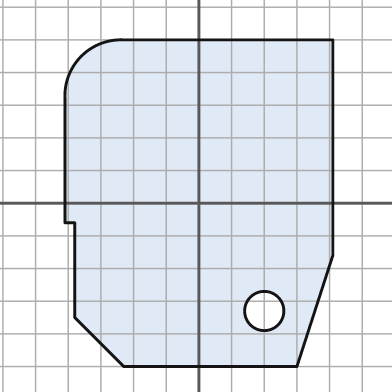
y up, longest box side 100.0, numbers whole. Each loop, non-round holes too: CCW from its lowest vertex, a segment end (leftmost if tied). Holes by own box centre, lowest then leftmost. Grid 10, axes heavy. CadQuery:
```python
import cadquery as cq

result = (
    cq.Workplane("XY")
    .moveTo(-23.0, -50.0)
    .lineTo(30.0, -50.0)
    .lineTo(41.0, -16.0)
    .lineTo(41.0, 50.0)
    .lineTo(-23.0, 50.0)
    .threePointArc((-36.0, 45.0), (-41.0, 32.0))
    .lineTo(-41.0, -6.0)
    .lineTo(-38.0, -6.0)
    .lineTo(-38.0, -35.0)
    .close()
    .moveTo(20.0, -33.0)
    .circle(6.0)
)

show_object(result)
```